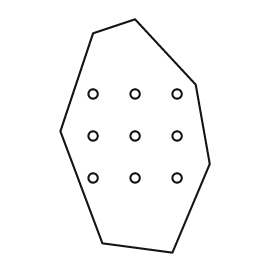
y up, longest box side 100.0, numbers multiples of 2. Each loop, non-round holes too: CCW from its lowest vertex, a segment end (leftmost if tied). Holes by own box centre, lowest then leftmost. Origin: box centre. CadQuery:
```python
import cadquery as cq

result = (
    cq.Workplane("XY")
    .moveTo(16.0, -50.0)
    .lineTo(32.0, -12.0)
    .lineTo(26.0, 22.0)
    .lineTo(0.0, 50.0)
    .lineTo(-18.0, 44.0)
    .lineTo(-32.0, 2.0)
    .lineTo(-14.0, -46.0)
    .close()
    .moveTo(-18.0, -18.0)
    .circle(2.0)
    .moveTo(0.0, -18.0)
    .circle(2.0)
    .moveTo(18.0, -18.0)
    .circle(2.0)
    .moveTo(-18.0, 0.0)
    .circle(2.0)
    .moveTo(0.0, 0.0)
    .circle(2.0)
    .moveTo(18.0, 0.0)
    .circle(2.0)
    .moveTo(-18.0, 18.0)
    .circle(2.0)
    .moveTo(0.0, 18.0)
    .circle(2.0)
    .moveTo(18.0, 18.0)
    .circle(2.0)
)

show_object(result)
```